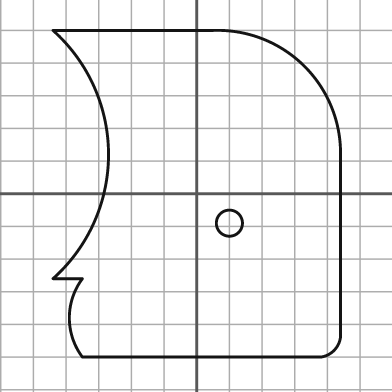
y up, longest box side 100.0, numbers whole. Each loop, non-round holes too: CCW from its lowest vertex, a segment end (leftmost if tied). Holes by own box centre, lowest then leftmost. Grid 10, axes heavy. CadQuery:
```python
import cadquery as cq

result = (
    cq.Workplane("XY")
    .moveTo(-35.0, -50.0)
    .lineTo(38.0, -50.0)
    .threePointArc((42.0, -48.0), (44.0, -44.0))
    .lineTo(44.0, 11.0)
    .threePointArc((33.0, 39.0), (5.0, 50.0))
    .lineTo(-44.0, 50.0)
    .threePointArc((-27.0, 12.0), (-44.0, -26.0))
    .lineTo(-35.0, -26.0)
    .threePointArc((-39.0, -38.0), (-35.0, -50.0))
    .close()
    .moveTo(10.0, -9.0)
    .circle(4.0)
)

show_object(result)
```